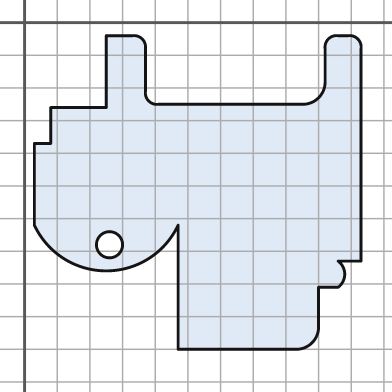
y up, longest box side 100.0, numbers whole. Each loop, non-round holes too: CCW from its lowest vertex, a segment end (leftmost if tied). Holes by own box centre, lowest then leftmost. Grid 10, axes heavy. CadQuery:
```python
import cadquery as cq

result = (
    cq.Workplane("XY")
    .moveTo(47.0, -100.0)
    .lineTo(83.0, -100.0)
    .threePointArc((88.0, -98.0), (90.0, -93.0))
    .lineTo(90.0, -81.0)
    .lineTo(96.0, -81.0)
    .threePointArc((98.0, -77.0), (96.0, -73.0))
    .lineTo(103.0, -73.0)
    .lineTo(103.0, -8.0)
    .threePointArc((102.0, -5.0), (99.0, -4.0))
    .lineTo(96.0, -4.0)
    .threePointArc((93.0, -5.0), (92.0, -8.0))
    .lineTo(92.0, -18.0)
    .threePointArc((90.0, -23.0), (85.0, -25.0))
    .lineTo(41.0, -25.0)
    .threePointArc((38.0, -24.0), (37.0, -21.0))
    .lineTo(37.0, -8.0)
    .threePointArc((36.0, -5.0), (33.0, -4.0))
    .lineTo(25.0, -4.0)
    .lineTo(25.0, -26.0)
    .lineTo(8.0, -26.0)
    .lineTo(8.0, -37.0)
    .lineTo(3.0, -37.0)
    .lineTo(3.0, -62.0)
    .threePointArc((25.0, -76.0), (47.0, -62.0))
    .close()
    .moveTo(26.0, -68.0)
    .circle(4.0)
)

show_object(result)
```